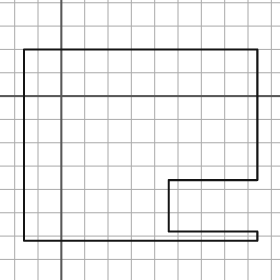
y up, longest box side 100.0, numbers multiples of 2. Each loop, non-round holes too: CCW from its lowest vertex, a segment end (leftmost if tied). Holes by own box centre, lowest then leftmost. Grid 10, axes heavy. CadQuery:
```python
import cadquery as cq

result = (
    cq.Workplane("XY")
    .moveTo(-16.0, -62.0)
    .lineTo(84.0, -62.0)
    .lineTo(84.0, -58.0)
    .lineTo(46.0, -58.0)
    .lineTo(46.0, -36.0)
    .lineTo(84.0, -36.0)
    .lineTo(84.0, 20.0)
    .lineTo(-16.0, 20.0)
    .close()
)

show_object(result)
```